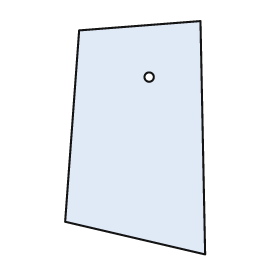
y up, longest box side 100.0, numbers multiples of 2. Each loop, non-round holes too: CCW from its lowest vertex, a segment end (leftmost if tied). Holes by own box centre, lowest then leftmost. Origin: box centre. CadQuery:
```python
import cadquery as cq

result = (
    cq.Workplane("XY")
    .moveTo(30.0, -50.0)
    .lineTo(28.0, 50.0)
    .lineTo(-24.0, 46.0)
    .lineTo(-30.0, -36.0)
    .close()
    .moveTo(6.0, 26.0)
    .circle(2.0)
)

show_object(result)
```